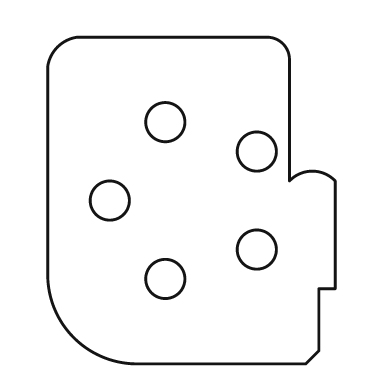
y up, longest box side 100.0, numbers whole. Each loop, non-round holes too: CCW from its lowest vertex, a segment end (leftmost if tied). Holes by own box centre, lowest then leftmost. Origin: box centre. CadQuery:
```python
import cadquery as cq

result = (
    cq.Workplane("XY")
    .moveTo(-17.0, -50.0)
    .lineTo(35.0, -50.0)
    .lineTo(39.0, -46.0)
    .lineTo(39.0, -27.0)
    .lineTo(44.0, -27.0)
    .lineTo(44.0, 6.0)
    .threePointArc((37.0, 9.0), (30.0, 6.0))
    .lineTo(30.0, 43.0)
    .threePointArc((28.0, 48.0), (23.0, 50.0))
    .lineTo(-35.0, 50.0)
    .threePointArc((-41.0, 47.0), (-44.0, 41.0))
    .lineTo(-44.0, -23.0)
    .threePointArc((-36.0, -42.0), (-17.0, -50.0))
    .close()
    .moveTo(-8.0, -24.0)
    .circle(6.0)
    .moveTo(20.0, -15.0)
    .circle(6.0)
    .moveTo(-25.0, 0.0)
    .circle(6.0)
    .moveTo(20.0, 15.0)
    .circle(6.0)
    .moveTo(-8.0, 24.0)
    .circle(6.0)
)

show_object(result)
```